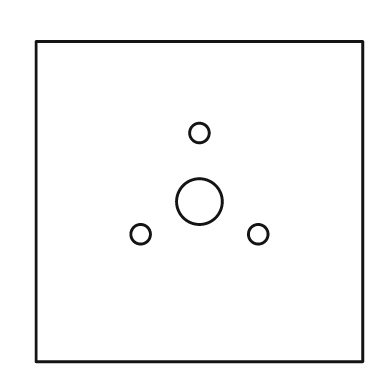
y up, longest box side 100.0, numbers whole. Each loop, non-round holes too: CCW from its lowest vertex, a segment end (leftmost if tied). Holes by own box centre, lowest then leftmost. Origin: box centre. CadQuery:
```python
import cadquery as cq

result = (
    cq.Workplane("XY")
    .moveTo(-50.0, -49.0)
    .lineTo(50.0, -49.0)
    .lineTo(50.0, 49.0)
    .lineTo(-50.0, 49.0)
    .close()
    .moveTo(-18.0, -10.0)
    .circle(3.0)
    .moveTo(18.0, -10.0)
    .circle(3.0)
    .moveTo(0.0, 0.0)
    .circle(7.0)
    .moveTo(0.0, 21.0)
    .circle(3.0)
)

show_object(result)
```